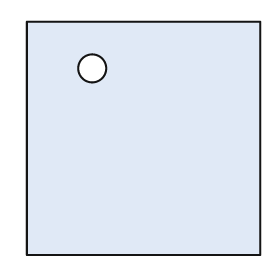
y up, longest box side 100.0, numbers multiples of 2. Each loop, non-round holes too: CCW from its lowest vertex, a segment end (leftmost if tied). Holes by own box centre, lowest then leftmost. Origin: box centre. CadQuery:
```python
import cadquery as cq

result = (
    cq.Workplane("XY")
    .moveTo(-50.0, -50.0)
    .lineTo(50.0, -50.0)
    .lineTo(50.0, 50.0)
    .lineTo(-50.0, 50.0)
    .close()
    .moveTo(-22.0, 30.0)
    .circle(6.0)
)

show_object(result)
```